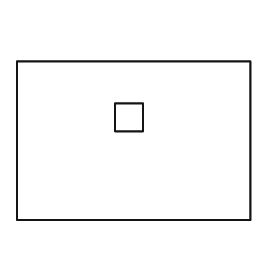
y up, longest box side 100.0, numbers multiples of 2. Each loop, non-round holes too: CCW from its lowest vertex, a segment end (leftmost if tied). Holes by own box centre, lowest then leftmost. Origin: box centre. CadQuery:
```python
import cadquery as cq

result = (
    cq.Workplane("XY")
    .moveTo(-50.0, -34.0)
    .lineTo(50.0, -34.0)
    .lineTo(50.0, 34.0)
    .lineTo(-50.0, 34.0)
    .close()
    .moveTo(-8.0, 4.0)
    .lineTo(4.0, 4.0)
    .lineTo(4.0, 16.0)
    .lineTo(-8.0, 16.0)
    .close()
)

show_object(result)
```